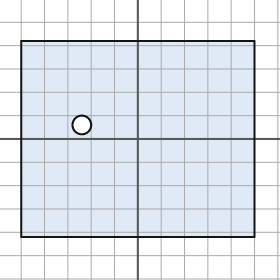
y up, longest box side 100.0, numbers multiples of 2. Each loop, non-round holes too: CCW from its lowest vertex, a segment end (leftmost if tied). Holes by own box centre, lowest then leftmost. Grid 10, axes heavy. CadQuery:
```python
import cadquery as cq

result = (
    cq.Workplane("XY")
    .moveTo(-50.0, -42.0)
    .lineTo(50.0, -42.0)
    .lineTo(50.0, 42.0)
    .lineTo(-50.0, 42.0)
    .close()
    .moveTo(-24.0, 6.0)
    .circle(4.0)
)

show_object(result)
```